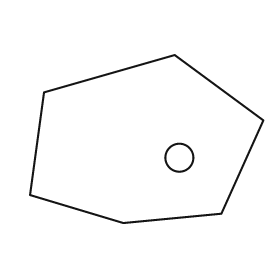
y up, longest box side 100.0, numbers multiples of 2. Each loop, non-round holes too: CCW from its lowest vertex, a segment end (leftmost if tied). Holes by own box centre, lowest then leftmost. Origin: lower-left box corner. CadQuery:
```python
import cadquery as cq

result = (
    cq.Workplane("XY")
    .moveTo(40.0, 0.0)
    .lineTo(82.0, 4.0)
    .lineTo(100.0, 44.0)
    .lineTo(62.0, 72.0)
    .lineTo(6.0, 56.0)
    .lineTo(0.0, 12.0)
    .close()
    .moveTo(64.0, 28.0)
    .circle(6.0)
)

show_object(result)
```